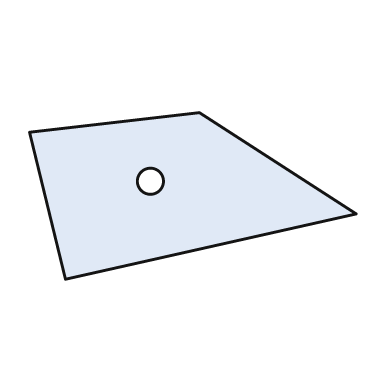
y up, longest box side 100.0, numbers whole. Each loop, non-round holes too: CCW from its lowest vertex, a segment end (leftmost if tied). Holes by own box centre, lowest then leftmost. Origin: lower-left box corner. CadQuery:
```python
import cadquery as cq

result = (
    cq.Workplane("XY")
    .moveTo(11.0, 0.0)
    .lineTo(100.0, 20.0)
    .lineTo(52.0, 51.0)
    .lineTo(0.0, 45.0)
    .close()
    .moveTo(37.0, 30.0)
    .circle(4.0)
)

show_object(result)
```